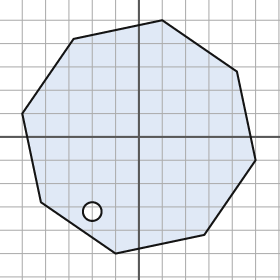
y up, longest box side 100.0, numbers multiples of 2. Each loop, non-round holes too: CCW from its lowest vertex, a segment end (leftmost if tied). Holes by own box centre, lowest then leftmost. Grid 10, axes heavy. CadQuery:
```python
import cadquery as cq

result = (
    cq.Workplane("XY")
    .moveTo(-10.0, -50.0)
    .lineTo(28.0, -42.0)
    .lineTo(50.0, -10.0)
    .lineTo(42.0, 28.0)
    .lineTo(10.0, 50.0)
    .lineTo(-28.0, 42.0)
    .lineTo(-50.0, 10.0)
    .lineTo(-42.0, -28.0)
    .close()
    .moveTo(-20.0, -32.0)
    .circle(4.0)
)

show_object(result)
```